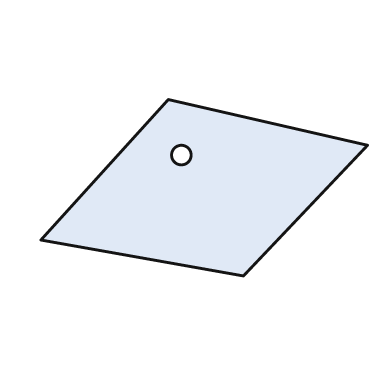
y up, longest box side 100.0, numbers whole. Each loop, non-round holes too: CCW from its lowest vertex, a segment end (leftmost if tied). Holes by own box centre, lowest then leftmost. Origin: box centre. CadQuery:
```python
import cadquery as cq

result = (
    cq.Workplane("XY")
    .moveTo(12.0, -27.0)
    .lineTo(50.0, 13.0)
    .lineTo(-11.0, 27.0)
    .lineTo(-50.0, -16.0)
    .close()
    .moveTo(-7.0, 10.0)
    .circle(3.0)
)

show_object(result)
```